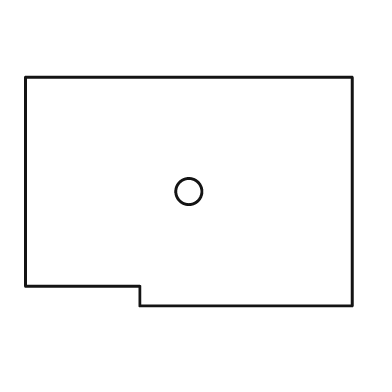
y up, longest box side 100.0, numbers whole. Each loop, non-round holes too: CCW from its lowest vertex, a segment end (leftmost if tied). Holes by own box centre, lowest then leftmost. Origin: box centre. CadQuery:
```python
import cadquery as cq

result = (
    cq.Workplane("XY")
    .moveTo(-15.0, -35.0)
    .lineTo(50.0, -35.0)
    .lineTo(50.0, 35.0)
    .lineTo(-50.0, 35.0)
    .lineTo(-50.0, -29.0)
    .lineTo(-15.0, -29.0)
    .close()
    .moveTo(0.0, 0.0)
    .circle(4.0)
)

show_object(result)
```